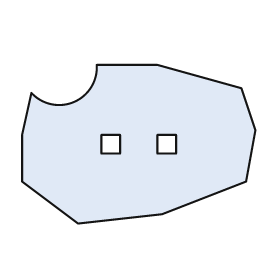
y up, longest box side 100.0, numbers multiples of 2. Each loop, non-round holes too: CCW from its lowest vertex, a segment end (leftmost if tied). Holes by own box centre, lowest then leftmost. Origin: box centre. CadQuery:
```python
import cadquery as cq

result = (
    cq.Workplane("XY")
    .moveTo(-26.0, -34.0)
    .lineTo(10.0, -30.0)
    .lineTo(46.0, -16.0)
    .lineTo(50.0, 6.0)
    .lineTo(44.0, 24.0)
    .lineTo(8.0, 34.0)
    .lineTo(-18.0, 34.0)
    .threePointArc((-28.0, 18.0), (-46.0, 22.0))
    .lineTo(-50.0, 4.0)
    .lineTo(-50.0, -16.0)
    .close()
    .moveTo(-16.0, -4.0)
    .lineTo(-8.0, -4.0)
    .lineTo(-8.0, 4.0)
    .lineTo(-16.0, 4.0)
    .close()
    .moveTo(8.0, -4.0)
    .lineTo(16.0, -4.0)
    .lineTo(16.0, 4.0)
    .lineTo(8.0, 4.0)
    .close()
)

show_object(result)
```